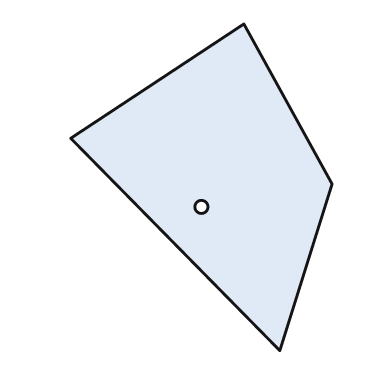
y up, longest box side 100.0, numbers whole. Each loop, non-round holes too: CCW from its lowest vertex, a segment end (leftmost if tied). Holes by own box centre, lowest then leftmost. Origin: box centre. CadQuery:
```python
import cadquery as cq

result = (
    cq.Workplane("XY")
    .moveTo(24.0, -50.0)
    .lineTo(40.0, 1.0)
    .lineTo(13.0, 50.0)
    .lineTo(-40.0, 15.0)
    .close()
    .moveTo(0.0, -6.0)
    .circle(2.0)
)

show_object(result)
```